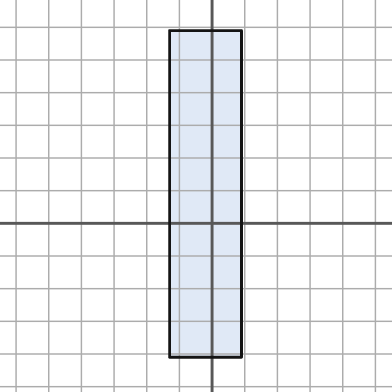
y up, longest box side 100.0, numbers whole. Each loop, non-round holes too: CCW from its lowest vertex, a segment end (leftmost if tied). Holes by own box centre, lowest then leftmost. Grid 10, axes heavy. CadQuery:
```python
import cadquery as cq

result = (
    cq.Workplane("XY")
    .moveTo(-13.0, -41.0)
    .lineTo(9.0, -41.0)
    .lineTo(9.0, 59.0)
    .lineTo(-13.0, 59.0)
    .close()
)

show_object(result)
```